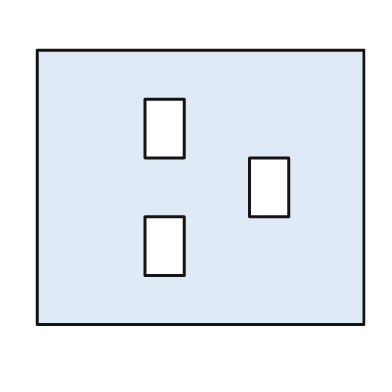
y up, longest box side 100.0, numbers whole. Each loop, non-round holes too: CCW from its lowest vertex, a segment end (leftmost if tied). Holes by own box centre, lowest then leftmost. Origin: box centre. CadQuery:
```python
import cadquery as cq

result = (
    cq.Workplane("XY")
    .moveTo(-50.0, -42.0)
    .lineTo(50.0, -42.0)
    .lineTo(50.0, 42.0)
    .lineTo(-50.0, 42.0)
    .close()
    .moveTo(-17.0, -27.0)
    .lineTo(-5.0, -27.0)
    .lineTo(-5.0, -9.0)
    .lineTo(-17.0, -9.0)
    .close()
    .moveTo(15.0, -9.0)
    .lineTo(27.0, -9.0)
    .lineTo(27.0, 9.0)
    .lineTo(15.0, 9.0)
    .close()
    .moveTo(-17.0, 9.0)
    .lineTo(-5.0, 9.0)
    .lineTo(-5.0, 27.0)
    .lineTo(-17.0, 27.0)
    .close()
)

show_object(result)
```